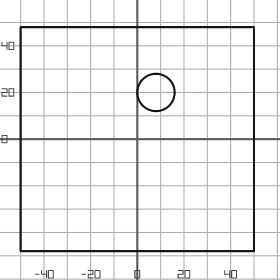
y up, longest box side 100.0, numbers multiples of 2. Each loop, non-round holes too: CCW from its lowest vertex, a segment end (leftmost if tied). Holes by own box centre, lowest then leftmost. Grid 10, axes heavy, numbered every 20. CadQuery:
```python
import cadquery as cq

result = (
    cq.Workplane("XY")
    .moveTo(-50.0, -48.0)
    .lineTo(50.0, -48.0)
    .lineTo(50.0, 48.0)
    .lineTo(-50.0, 48.0)
    .close()
    .moveTo(8.0, 20.0)
    .circle(8.0)
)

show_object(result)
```